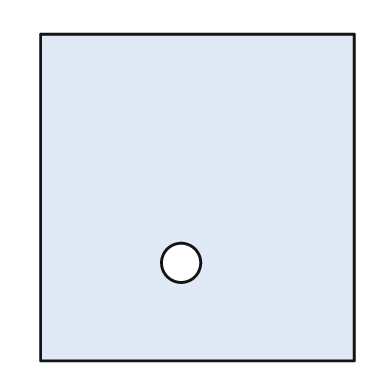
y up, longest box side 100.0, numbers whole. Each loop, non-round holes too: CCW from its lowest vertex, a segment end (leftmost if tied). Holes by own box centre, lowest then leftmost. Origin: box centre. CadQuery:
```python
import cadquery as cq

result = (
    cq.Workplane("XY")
    .moveTo(-48.0, -50.0)
    .lineTo(48.0, -50.0)
    .lineTo(48.0, 50.0)
    .lineTo(-48.0, 50.0)
    .close()
    .moveTo(-5.0, -20.0)
    .circle(6.0)
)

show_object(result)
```